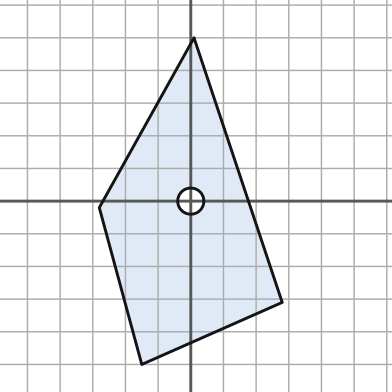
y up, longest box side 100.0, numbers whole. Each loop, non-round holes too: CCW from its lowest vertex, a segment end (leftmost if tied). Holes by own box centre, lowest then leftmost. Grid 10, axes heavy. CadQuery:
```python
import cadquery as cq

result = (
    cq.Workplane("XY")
    .moveTo(-15.0, -50.0)
    .lineTo(28.0, -31.0)
    .lineTo(1.0, 50.0)
    .lineTo(-28.0, -2.0)
    .close()
    .moveTo(0.0, 0.0)
    .circle(4.0)
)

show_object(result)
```